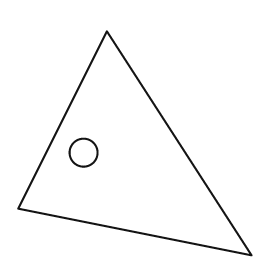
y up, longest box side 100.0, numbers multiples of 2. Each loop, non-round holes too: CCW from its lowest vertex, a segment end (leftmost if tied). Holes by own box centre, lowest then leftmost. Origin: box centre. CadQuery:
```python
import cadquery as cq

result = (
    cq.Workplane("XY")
    .moveTo(50.0, -48.0)
    .lineTo(-12.0, 48.0)
    .lineTo(-50.0, -28.0)
    .close()
    .moveTo(-22.0, -4.0)
    .circle(6.0)
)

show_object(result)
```